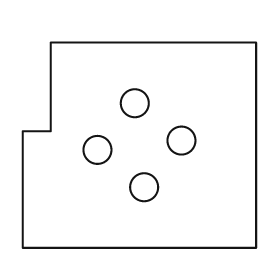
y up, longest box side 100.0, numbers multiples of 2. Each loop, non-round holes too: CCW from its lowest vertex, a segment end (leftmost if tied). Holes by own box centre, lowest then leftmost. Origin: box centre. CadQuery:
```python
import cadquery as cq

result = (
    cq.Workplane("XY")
    .moveTo(-50.0, -44.0)
    .lineTo(50.0, -44.0)
    .lineTo(50.0, 44.0)
    .lineTo(-38.0, 44.0)
    .lineTo(-38.0, 6.0)
    .lineTo(-50.0, 6.0)
    .close()
    .moveTo(2.0, -18.0)
    .circle(6.0)
    .moveTo(-18.0, -2.0)
    .circle(6.0)
    .moveTo(18.0, 2.0)
    .circle(6.0)
    .moveTo(-2.0, 18.0)
    .circle(6.0)
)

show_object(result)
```